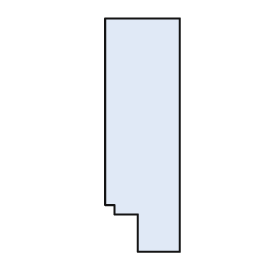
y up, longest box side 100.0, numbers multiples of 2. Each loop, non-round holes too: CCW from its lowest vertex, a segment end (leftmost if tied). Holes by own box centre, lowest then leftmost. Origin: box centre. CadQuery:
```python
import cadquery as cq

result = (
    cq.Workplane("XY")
    .moveTo(-2.0, -50.0)
    .lineTo(16.0, -50.0)
    .lineTo(16.0, 50.0)
    .lineTo(-16.0, 50.0)
    .lineTo(-16.0, -30.0)
    .lineTo(-12.0, -30.0)
    .lineTo(-12.0, -34.0)
    .lineTo(-2.0, -34.0)
    .close()
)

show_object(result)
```